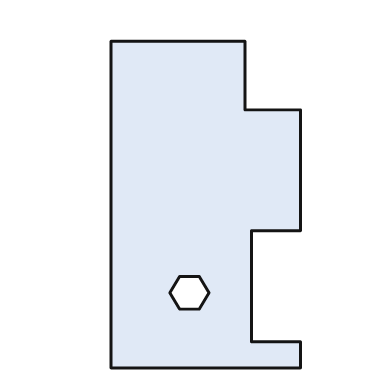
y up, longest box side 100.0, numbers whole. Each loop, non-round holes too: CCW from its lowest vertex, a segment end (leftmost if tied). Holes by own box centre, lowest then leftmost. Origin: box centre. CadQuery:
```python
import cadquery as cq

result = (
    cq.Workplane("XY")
    .moveTo(-29.0, -50.0)
    .lineTo(29.0, -50.0)
    .lineTo(29.0, -42.0)
    .lineTo(14.0, -42.0)
    .lineTo(14.0, -8.0)
    .lineTo(29.0, -8.0)
    .lineTo(29.0, 29.0)
    .lineTo(12.0, 29.0)
    .lineTo(12.0, 50.0)
    .lineTo(-29.0, 50.0)
    .close()
    .moveTo(-8.0, -32.0)
    .lineTo(-2.0, -32.0)
    .lineTo(1.0, -27.0)
    .lineTo(-2.0, -22.0)
    .lineTo(-8.0, -22.0)
    .lineTo(-11.0, -27.0)
    .close()
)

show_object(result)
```